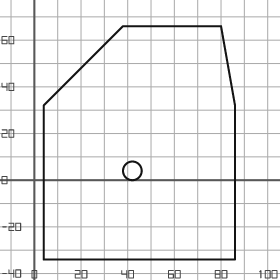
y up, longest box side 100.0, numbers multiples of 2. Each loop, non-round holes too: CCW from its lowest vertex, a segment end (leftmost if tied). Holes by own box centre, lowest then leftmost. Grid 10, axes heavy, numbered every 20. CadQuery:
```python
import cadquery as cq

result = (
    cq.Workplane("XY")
    .moveTo(4.0, -34.0)
    .lineTo(86.0, -34.0)
    .lineTo(86.0, 32.0)
    .lineTo(80.0, 66.0)
    .lineTo(38.0, 66.0)
    .lineTo(4.0, 32.0)
    .close()
    .moveTo(42.0, 4.0)
    .circle(4.0)
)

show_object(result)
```